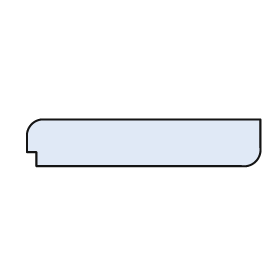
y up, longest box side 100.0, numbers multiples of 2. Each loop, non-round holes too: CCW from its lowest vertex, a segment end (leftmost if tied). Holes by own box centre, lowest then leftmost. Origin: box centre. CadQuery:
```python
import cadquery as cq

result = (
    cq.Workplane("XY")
    .moveTo(-46.0, -10.0)
    .lineTo(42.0, -10.0)
    .threePointArc((48.0, -8.0), (50.0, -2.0))
    .lineTo(50.0, 10.0)
    .lineTo(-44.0, 10.0)
    .threePointArc((-48.0, 8.0), (-50.0, 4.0))
    .lineTo(-50.0, -4.0)
    .lineTo(-46.0, -4.0)
    .close()
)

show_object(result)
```